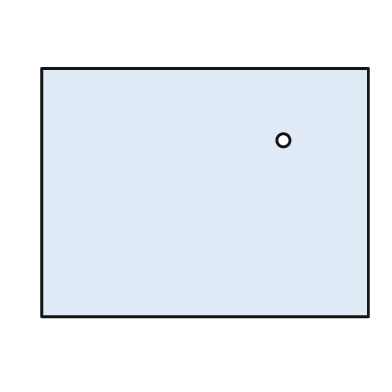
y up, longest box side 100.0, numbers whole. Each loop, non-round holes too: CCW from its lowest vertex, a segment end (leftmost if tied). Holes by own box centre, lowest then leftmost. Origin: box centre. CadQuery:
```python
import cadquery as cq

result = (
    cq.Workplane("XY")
    .moveTo(-50.0, -38.0)
    .lineTo(50.0, -38.0)
    .lineTo(50.0, 38.0)
    .lineTo(-50.0, 38.0)
    .close()
    .moveTo(24.0, 16.0)
    .circle(2.0)
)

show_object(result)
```